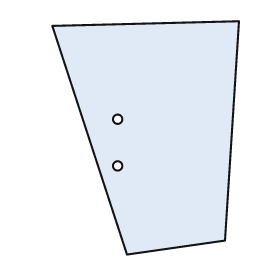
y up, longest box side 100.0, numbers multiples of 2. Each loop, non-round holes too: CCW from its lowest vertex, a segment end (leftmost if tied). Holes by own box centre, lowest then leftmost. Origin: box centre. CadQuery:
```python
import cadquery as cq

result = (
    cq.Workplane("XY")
    .moveTo(-8.0, -50.0)
    .lineTo(34.0, -44.0)
    .lineTo(40.0, 50.0)
    .lineTo(-40.0, 48.0)
    .close()
    .moveTo(-12.0, -12.0)
    .circle(2.0)
    .moveTo(-12.0, 8.0)
    .circle(2.0)
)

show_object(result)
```